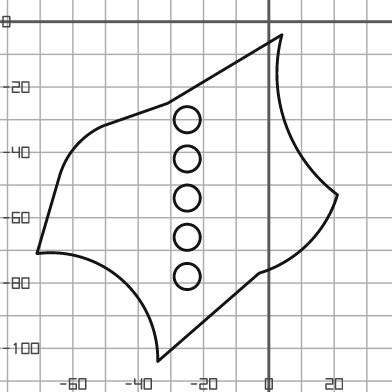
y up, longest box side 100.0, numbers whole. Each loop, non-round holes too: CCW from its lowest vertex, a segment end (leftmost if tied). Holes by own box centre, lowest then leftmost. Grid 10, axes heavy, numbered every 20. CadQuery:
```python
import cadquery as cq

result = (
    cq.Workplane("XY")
    .moveTo(-34.0, -104.0)
    .lineTo(-3.0, -77.0)
    .threePointArc((12.0, -68.0), (21.0, -53.0))
    .threePointArc((5.0, -31.0), (4.0, -4.0))
    .lineTo(-31.0, -25.0)
    .lineTo(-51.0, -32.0)
    .threePointArc((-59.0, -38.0), (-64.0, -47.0))
    .lineTo(-71.0, -71.0)
    .threePointArc((-45.0, -79.0), (-34.0, -104.0))
    .close()
    .moveTo(-25.0, -78.0)
    .circle(4.0)
    .moveTo(-25.0, -66.0)
    .circle(4.0)
    .moveTo(-25.0, -54.0)
    .circle(4.0)
    .moveTo(-25.0, -42.0)
    .circle(4.0)
    .moveTo(-25.0, -30.0)
    .circle(4.0)
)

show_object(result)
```